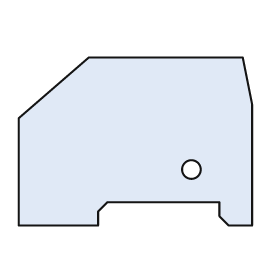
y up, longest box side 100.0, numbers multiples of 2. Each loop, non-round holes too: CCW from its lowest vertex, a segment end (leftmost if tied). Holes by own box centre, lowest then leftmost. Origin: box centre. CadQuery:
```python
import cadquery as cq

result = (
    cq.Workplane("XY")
    .moveTo(-50.0, -36.0)
    .lineTo(-16.0, -36.0)
    .lineTo(-16.0, -30.0)
    .lineTo(-12.0, -26.0)
    .lineTo(36.0, -26.0)
    .lineTo(36.0, -32.0)
    .lineTo(40.0, -36.0)
    .lineTo(50.0, -36.0)
    .lineTo(50.0, 16.0)
    .lineTo(46.0, 36.0)
    .lineTo(-20.0, 36.0)
    .lineTo(-50.0, 10.0)
    .close()
    .moveTo(24.0, -12.0)
    .circle(4.0)
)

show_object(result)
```